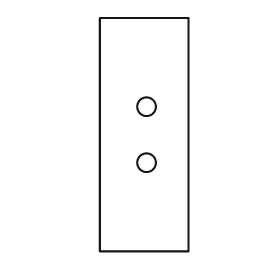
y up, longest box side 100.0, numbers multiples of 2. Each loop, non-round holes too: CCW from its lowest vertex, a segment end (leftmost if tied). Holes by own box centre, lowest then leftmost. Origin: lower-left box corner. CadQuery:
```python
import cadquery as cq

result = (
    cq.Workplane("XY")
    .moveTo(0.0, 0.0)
    .lineTo(38.0, 0.0)
    .lineTo(38.0, 100.0)
    .lineTo(0.0, 100.0)
    .close()
    .moveTo(20.0, 38.0)
    .circle(4.0)
    .moveTo(20.0, 62.0)
    .circle(4.0)
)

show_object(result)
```